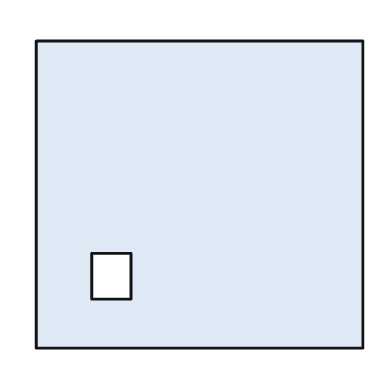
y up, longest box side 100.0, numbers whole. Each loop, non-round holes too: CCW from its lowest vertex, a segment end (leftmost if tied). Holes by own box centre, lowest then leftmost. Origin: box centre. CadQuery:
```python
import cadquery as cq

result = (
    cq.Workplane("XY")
    .moveTo(-50.0, -47.0)
    .lineTo(50.0, -47.0)
    .lineTo(50.0, 47.0)
    .lineTo(-50.0, 47.0)
    .close()
    .moveTo(-33.0, -32.0)
    .lineTo(-21.0, -32.0)
    .lineTo(-21.0, -18.0)
    .lineTo(-33.0, -18.0)
    .close()
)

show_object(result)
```